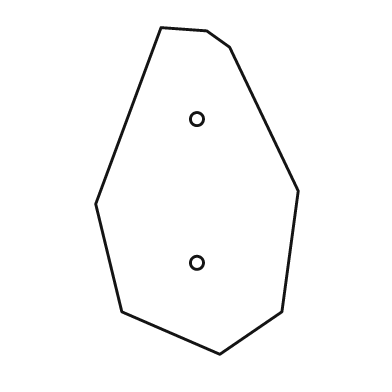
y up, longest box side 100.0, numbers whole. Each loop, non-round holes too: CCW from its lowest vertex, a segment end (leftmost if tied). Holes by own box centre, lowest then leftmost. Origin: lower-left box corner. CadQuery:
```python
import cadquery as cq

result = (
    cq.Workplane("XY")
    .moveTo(38.0, 0.0)
    .lineTo(57.0, 13.0)
    .lineTo(62.0, 50.0)
    .lineTo(41.0, 94.0)
    .lineTo(34.0, 99.0)
    .lineTo(20.0, 100.0)
    .lineTo(0.0, 46.0)
    .lineTo(8.0, 13.0)
    .close()
    .moveTo(31.0, 28.0)
    .circle(2.0)
    .moveTo(31.0, 72.0)
    .circle(2.0)
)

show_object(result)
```